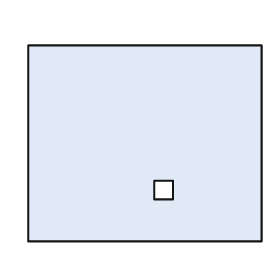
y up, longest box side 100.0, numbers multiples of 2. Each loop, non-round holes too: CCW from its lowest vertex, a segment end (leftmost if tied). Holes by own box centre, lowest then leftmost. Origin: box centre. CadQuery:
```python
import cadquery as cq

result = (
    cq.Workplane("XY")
    .moveTo(-50.0, -42.0)
    .lineTo(50.0, -42.0)
    .lineTo(50.0, 42.0)
    .lineTo(-50.0, 42.0)
    .close()
    .moveTo(4.0, -24.0)
    .lineTo(12.0, -24.0)
    .lineTo(12.0, -16.0)
    .lineTo(4.0, -16.0)
    .close()
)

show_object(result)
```